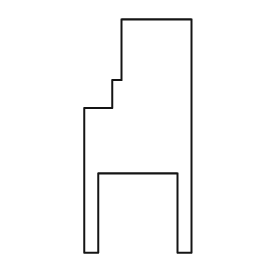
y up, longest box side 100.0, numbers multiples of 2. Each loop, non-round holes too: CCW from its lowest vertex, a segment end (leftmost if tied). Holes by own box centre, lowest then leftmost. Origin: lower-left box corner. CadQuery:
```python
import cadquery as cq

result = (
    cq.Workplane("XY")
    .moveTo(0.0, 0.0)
    .lineTo(6.0, 0.0)
    .lineTo(6.0, 34.0)
    .lineTo(40.0, 34.0)
    .lineTo(40.0, 0.0)
    .lineTo(46.0, 0.0)
    .lineTo(46.0, 100.0)
    .lineTo(16.0, 100.0)
    .lineTo(16.0, 74.0)
    .lineTo(12.0, 74.0)
    .lineTo(12.0, 62.0)
    .lineTo(0.0, 62.0)
    .close()
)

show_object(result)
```